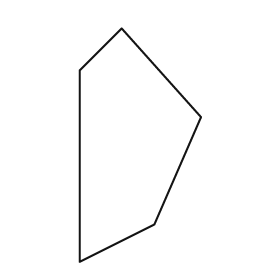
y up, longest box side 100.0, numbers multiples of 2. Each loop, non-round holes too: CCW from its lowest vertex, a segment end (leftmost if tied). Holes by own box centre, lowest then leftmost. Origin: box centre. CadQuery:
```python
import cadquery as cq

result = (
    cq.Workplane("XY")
    .moveTo(-26.0, -50.0)
    .lineTo(6.0, -34.0)
    .lineTo(26.0, 12.0)
    .lineTo(-8.0, 50.0)
    .lineTo(-26.0, 32.0)
    .close()
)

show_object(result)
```